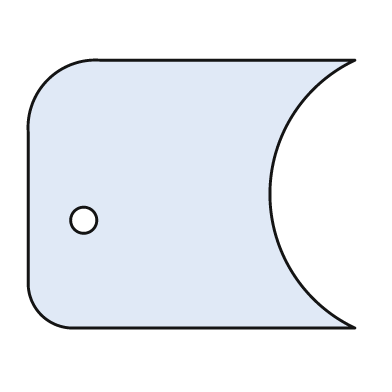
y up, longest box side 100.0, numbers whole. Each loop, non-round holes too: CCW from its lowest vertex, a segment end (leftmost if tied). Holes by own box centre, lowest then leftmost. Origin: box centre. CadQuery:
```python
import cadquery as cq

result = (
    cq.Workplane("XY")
    .moveTo(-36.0, -41.0)
    .lineTo(50.0, -41.0)
    .threePointArc((24.0, 0.0), (50.0, 41.0))
    .lineTo(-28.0, 41.0)
    .threePointArc((-44.0, 35.0), (-50.0, 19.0))
    .lineTo(-50.0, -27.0)
    .threePointArc((-46.0, -37.0), (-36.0, -41.0))
    .close()
    .moveTo(-33.0, -8.0)
    .circle(4.0)
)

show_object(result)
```